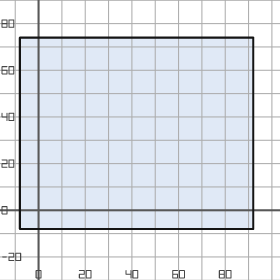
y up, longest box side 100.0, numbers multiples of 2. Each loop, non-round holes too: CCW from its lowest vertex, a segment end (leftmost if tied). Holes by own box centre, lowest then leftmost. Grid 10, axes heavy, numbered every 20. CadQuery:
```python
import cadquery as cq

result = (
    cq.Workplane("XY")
    .moveTo(-8.0, -8.0)
    .lineTo(92.0, -8.0)
    .lineTo(92.0, 74.0)
    .lineTo(-8.0, 74.0)
    .close()
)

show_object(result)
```